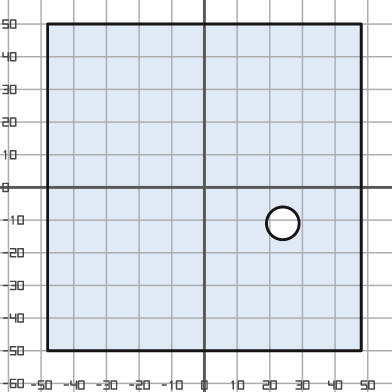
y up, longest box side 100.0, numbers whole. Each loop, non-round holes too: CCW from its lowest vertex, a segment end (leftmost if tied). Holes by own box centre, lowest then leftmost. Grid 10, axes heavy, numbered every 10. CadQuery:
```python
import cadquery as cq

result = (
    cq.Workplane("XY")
    .moveTo(-48.0, -50.0)
    .lineTo(48.0, -50.0)
    .lineTo(48.0, 50.0)
    .lineTo(-48.0, 50.0)
    .close()
    .moveTo(24.0, -11.0)
    .circle(5.0)
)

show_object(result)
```